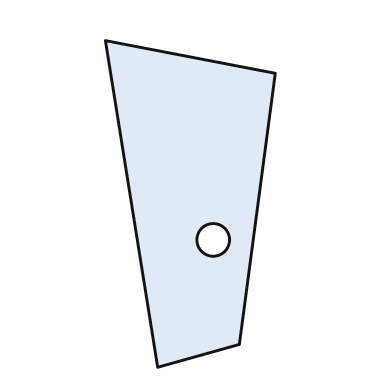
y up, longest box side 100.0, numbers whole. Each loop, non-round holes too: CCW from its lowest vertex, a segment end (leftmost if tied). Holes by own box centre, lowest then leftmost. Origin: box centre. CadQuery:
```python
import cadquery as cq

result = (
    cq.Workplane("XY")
    .moveTo(-10.0, -50.0)
    .lineTo(15.0, -43.0)
    .lineTo(26.0, 40.0)
    .lineTo(-26.0, 50.0)
    .close()
    .moveTo(7.0, -11.0)
    .circle(5.0)
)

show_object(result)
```